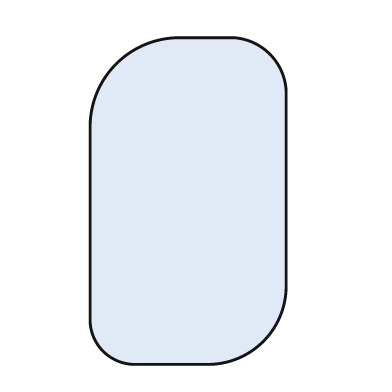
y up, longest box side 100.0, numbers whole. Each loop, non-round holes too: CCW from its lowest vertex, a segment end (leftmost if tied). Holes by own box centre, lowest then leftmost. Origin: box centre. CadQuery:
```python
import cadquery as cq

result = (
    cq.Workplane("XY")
    .moveTo(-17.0, -50.0)
    .lineTo(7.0, -50.0)
    .threePointArc((23.0, -43.0), (30.0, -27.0))
    .lineTo(30.0, 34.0)
    .threePointArc((25.0, 45.0), (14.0, 50.0))
    .lineTo(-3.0, 50.0)
    .threePointArc((-22.0, 42.0), (-30.0, 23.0))
    .lineTo(-30.0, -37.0)
    .threePointArc((-26.0, -46.0), (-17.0, -50.0))
    .close()
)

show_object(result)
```